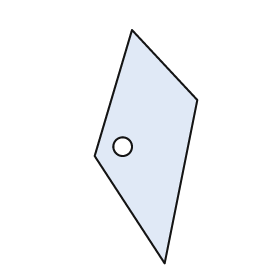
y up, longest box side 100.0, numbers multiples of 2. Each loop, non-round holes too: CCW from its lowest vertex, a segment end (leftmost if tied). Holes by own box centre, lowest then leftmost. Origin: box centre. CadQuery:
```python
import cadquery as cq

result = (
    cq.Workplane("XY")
    .moveTo(8.0, -50.0)
    .lineTo(22.0, 20.0)
    .lineTo(-6.0, 50.0)
    .lineTo(-22.0, -4.0)
    .close()
    .moveTo(-10.0, 0.0)
    .circle(4.0)
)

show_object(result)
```